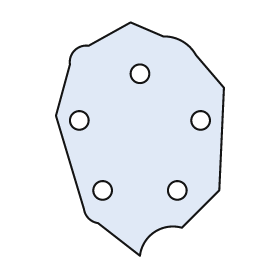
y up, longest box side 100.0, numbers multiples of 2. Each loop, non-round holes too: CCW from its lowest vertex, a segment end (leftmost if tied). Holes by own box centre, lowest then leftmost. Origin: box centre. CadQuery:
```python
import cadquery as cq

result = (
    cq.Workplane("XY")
    .moveTo(0.0, -50.0)
    .threePointArc((6.0, -40.0), (18.0, -38.0))
    .lineTo(34.0, -22.0)
    .lineTo(36.0, 22.0)
    .lineTo(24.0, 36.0)
    .threePointArc((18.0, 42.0), (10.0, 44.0))
    .lineTo(-4.0, 50.0)
    .lineTo(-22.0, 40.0)
    .threePointArc((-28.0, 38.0), (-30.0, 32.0))
    .lineTo(-36.0, 10.0)
    .lineTo(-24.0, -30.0)
    .threePointArc((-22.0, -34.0), (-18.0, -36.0))
    .close()
    .moveTo(-16.0, -22.0)
    .circle(4.0)
    .moveTo(16.0, -22.0)
    .circle(4.0)
    .moveTo(-26.0, 8.0)
    .circle(4.0)
    .moveTo(26.0, 8.0)
    .circle(4.0)
    .moveTo(0.0, 28.0)
    .circle(4.0)
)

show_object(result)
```